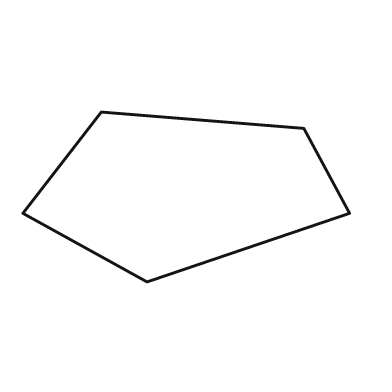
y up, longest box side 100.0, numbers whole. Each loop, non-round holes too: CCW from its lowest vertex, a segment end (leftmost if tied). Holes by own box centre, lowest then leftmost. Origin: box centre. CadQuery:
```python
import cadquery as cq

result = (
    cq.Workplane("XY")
    .moveTo(-12.0, -26.0)
    .lineTo(50.0, -5.0)
    .lineTo(36.0, 21.0)
    .lineTo(-26.0, 26.0)
    .lineTo(-50.0, -5.0)
    .close()
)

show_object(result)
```